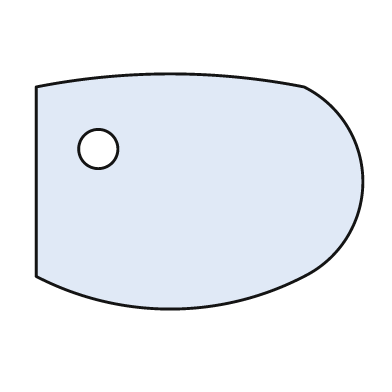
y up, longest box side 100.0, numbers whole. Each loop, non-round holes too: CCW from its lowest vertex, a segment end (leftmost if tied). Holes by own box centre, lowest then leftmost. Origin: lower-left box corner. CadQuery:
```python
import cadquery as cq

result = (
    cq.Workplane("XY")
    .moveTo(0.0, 10.0)
    .threePointArc((41.0, 0.0), (82.0, 10.0))
    .threePointArc((100.0, 39.0), (82.0, 68.0))
    .threePointArc((41.0, 72.0), (0.0, 68.0))
    .close()
    .moveTo(19.0, 49.0)
    .circle(6.0)
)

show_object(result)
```